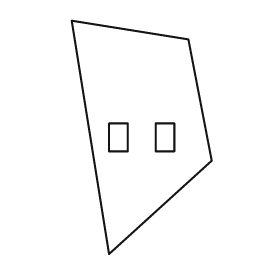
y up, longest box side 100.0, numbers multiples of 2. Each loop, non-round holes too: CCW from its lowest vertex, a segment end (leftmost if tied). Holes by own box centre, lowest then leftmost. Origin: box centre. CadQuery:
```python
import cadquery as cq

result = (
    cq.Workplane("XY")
    .moveTo(-14.0, -50.0)
    .lineTo(30.0, -10.0)
    .lineTo(20.0, 42.0)
    .lineTo(-30.0, 50.0)
    .close()
    .moveTo(-14.0, -6.0)
    .lineTo(-6.0, -6.0)
    .lineTo(-6.0, 6.0)
    .lineTo(-14.0, 6.0)
    .close()
    .moveTo(6.0, -6.0)
    .lineTo(14.0, -6.0)
    .lineTo(14.0, 6.0)
    .lineTo(6.0, 6.0)
    .close()
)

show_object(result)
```